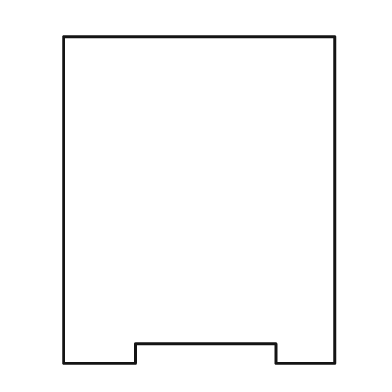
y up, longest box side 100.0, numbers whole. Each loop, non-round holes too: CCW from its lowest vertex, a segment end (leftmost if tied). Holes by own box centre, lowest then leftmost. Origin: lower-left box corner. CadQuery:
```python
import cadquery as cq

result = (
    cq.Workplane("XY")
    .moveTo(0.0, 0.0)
    .lineTo(22.0, 0.0)
    .lineTo(22.0, 6.0)
    .lineTo(65.0, 6.0)
    .lineTo(65.0, 0.0)
    .lineTo(83.0, 0.0)
    .lineTo(83.0, 100.0)
    .lineTo(0.0, 100.0)
    .close()
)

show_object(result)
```